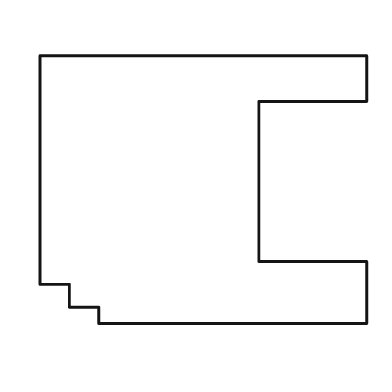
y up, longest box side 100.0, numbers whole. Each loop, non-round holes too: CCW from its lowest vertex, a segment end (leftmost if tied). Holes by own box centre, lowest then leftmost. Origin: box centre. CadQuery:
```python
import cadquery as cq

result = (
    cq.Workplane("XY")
    .moveTo(-32.0, -41.0)
    .lineTo(50.0, -41.0)
    .lineTo(50.0, -22.0)
    .lineTo(17.0, -22.0)
    .lineTo(17.0, 27.0)
    .lineTo(50.0, 27.0)
    .lineTo(50.0, 41.0)
    .lineTo(-50.0, 41.0)
    .lineTo(-50.0, -29.0)
    .lineTo(-41.0, -29.0)
    .lineTo(-41.0, -36.0)
    .lineTo(-32.0, -36.0)
    .close()
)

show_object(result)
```